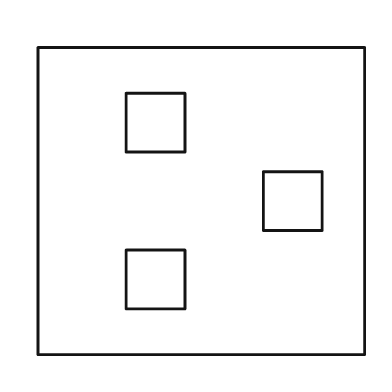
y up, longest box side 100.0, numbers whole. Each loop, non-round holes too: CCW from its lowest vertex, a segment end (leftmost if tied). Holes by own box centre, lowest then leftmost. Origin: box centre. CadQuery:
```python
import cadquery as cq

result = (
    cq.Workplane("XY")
    .moveTo(-50.0, -47.0)
    .lineTo(50.0, -47.0)
    .lineTo(50.0, 47.0)
    .lineTo(-50.0, 47.0)
    .close()
    .moveTo(-23.0, -33.0)
    .lineTo(-5.0, -33.0)
    .lineTo(-5.0, -15.0)
    .lineTo(-23.0, -15.0)
    .close()
    .moveTo(19.0, -9.0)
    .lineTo(37.0, -9.0)
    .lineTo(37.0, 9.0)
    .lineTo(19.0, 9.0)
    .close()
    .moveTo(-23.0, 15.0)
    .lineTo(-5.0, 15.0)
    .lineTo(-5.0, 33.0)
    .lineTo(-23.0, 33.0)
    .close()
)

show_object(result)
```